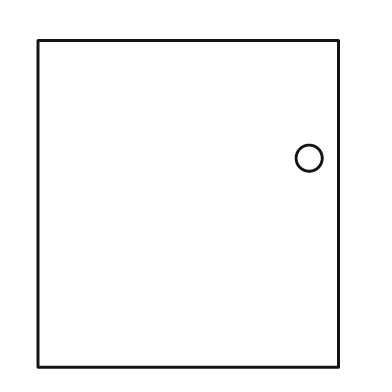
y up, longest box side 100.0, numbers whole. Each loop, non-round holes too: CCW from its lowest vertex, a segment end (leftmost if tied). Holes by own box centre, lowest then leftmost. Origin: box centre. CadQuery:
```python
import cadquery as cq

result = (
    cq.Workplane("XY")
    .moveTo(-46.0, -50.0)
    .lineTo(46.0, -50.0)
    .lineTo(46.0, 50.0)
    .lineTo(-46.0, 50.0)
    .close()
    .moveTo(37.0, 14.0)
    .circle(4.0)
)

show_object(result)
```